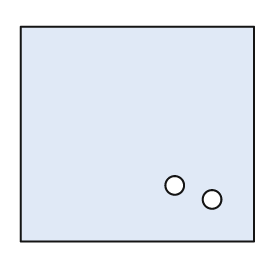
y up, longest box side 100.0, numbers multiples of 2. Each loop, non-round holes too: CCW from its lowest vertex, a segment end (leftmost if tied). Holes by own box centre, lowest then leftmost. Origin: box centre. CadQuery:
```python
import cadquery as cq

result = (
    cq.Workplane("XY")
    .moveTo(-50.0, -46.0)
    .lineTo(50.0, -46.0)
    .lineTo(50.0, 46.0)
    .lineTo(-50.0, 46.0)
    .close()
    .moveTo(32.0, -28.0)
    .circle(4.0)
    .moveTo(16.0, -22.0)
    .circle(4.0)
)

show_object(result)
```